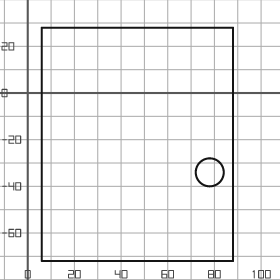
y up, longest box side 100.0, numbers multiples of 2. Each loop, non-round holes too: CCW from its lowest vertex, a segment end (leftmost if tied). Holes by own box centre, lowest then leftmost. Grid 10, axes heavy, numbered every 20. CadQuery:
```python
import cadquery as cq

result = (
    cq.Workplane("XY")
    .moveTo(6.0, -72.0)
    .lineTo(88.0, -72.0)
    .lineTo(88.0, 28.0)
    .lineTo(6.0, 28.0)
    .close()
    .moveTo(78.0, -34.0)
    .circle(6.0)
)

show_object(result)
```